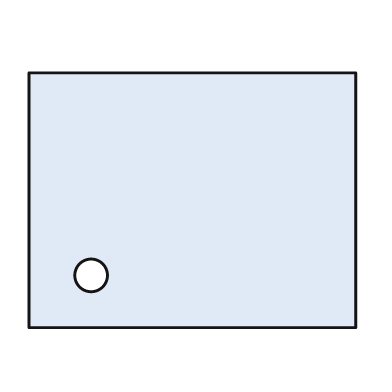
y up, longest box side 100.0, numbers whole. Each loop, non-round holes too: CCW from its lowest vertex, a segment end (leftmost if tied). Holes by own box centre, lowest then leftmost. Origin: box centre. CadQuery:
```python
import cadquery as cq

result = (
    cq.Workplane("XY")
    .moveTo(-50.0, -39.0)
    .lineTo(50.0, -39.0)
    .lineTo(50.0, 39.0)
    .lineTo(-50.0, 39.0)
    .close()
    .moveTo(-31.0, -23.0)
    .circle(5.0)
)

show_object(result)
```